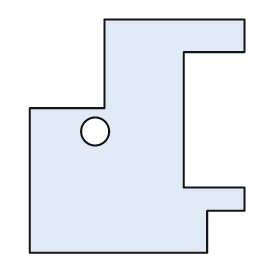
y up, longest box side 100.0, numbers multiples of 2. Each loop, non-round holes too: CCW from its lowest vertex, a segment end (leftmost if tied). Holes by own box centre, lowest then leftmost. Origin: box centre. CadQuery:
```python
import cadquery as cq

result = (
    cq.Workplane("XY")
    .moveTo(-46.0, -50.0)
    .lineTo(30.0, -50.0)
    .lineTo(30.0, -32.0)
    .lineTo(46.0, -32.0)
    .lineTo(46.0, -22.0)
    .lineTo(20.0, -22.0)
    .lineTo(20.0, 36.0)
    .lineTo(46.0, 36.0)
    .lineTo(46.0, 50.0)
    .lineTo(-14.0, 50.0)
    .lineTo(-14.0, 12.0)
    .lineTo(-46.0, 12.0)
    .close()
    .moveTo(-18.0, 2.0)
    .circle(6.0)
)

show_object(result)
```